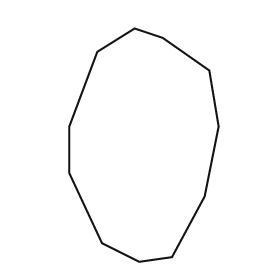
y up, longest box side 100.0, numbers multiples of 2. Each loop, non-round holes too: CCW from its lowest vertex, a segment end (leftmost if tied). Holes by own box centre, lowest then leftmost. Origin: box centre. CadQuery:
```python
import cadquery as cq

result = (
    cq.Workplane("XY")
    .moveTo(-2.0, -50.0)
    .lineTo(12.0, -48.0)
    .lineTo(26.0, -22.0)
    .lineTo(32.0, 8.0)
    .lineTo(28.0, 32.0)
    .lineTo(8.0, 46.0)
    .lineTo(-4.0, 50.0)
    .lineTo(-20.0, 40.0)
    .lineTo(-32.0, 8.0)
    .lineTo(-32.0, -12.0)
    .lineTo(-18.0, -42.0)
    .close()
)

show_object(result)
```